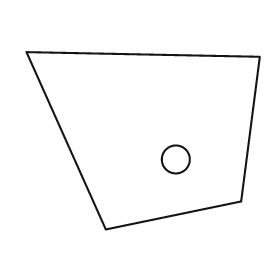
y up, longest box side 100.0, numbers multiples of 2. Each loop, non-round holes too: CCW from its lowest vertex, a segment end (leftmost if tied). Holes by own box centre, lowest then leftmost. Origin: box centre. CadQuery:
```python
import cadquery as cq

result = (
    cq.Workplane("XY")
    .moveTo(-16.0, -38.0)
    .lineTo(42.0, -26.0)
    .lineTo(50.0, 36.0)
    .lineTo(-50.0, 38.0)
    .close()
    .moveTo(14.0, -8.0)
    .circle(6.0)
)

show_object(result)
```